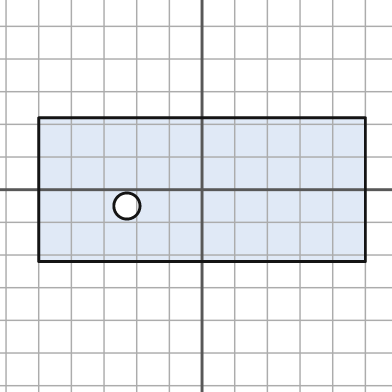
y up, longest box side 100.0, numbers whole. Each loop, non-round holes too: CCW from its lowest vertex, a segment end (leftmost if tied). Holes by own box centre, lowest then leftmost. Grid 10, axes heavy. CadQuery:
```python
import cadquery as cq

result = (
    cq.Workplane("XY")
    .moveTo(-50.0, -22.0)
    .lineTo(50.0, -22.0)
    .lineTo(50.0, 22.0)
    .lineTo(-50.0, 22.0)
    .close()
    .moveTo(-23.0, -5.0)
    .circle(4.0)
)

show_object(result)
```